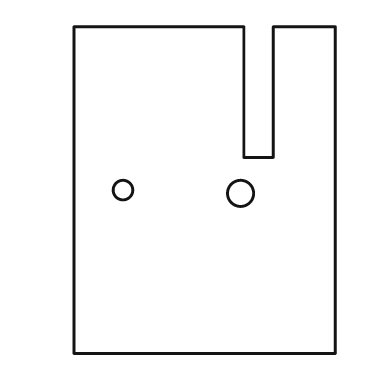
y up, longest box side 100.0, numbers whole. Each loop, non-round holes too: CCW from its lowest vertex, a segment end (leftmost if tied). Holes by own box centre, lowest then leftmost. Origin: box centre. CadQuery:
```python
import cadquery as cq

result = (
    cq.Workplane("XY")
    .moveTo(-40.0, -50.0)
    .lineTo(40.0, -50.0)
    .lineTo(40.0, 50.0)
    .lineTo(21.0, 50.0)
    .lineTo(21.0, 10.0)
    .lineTo(12.0, 10.0)
    .lineTo(12.0, 50.0)
    .lineTo(-40.0, 50.0)
    .close()
    .moveTo(11.0, -1.0)
    .circle(4.0)
    .moveTo(-25.0, 0.0)
    .circle(3.0)
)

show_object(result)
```